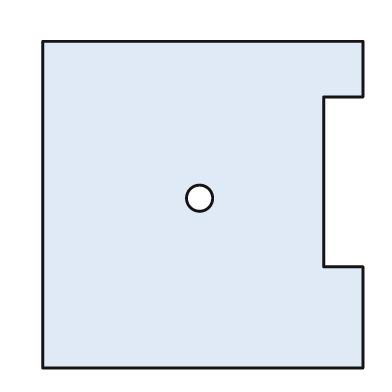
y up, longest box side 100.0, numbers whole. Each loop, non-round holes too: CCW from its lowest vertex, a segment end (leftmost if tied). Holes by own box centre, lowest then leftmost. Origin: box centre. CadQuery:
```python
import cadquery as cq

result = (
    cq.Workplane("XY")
    .moveTo(-49.0, -50.0)
    .lineTo(49.0, -50.0)
    .lineTo(49.0, -19.0)
    .lineTo(37.0, -19.0)
    .lineTo(37.0, 33.0)
    .lineTo(49.0, 33.0)
    .lineTo(49.0, 50.0)
    .lineTo(-49.0, 50.0)
    .close()
    .moveTo(-1.0, 2.0)
    .circle(4.0)
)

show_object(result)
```